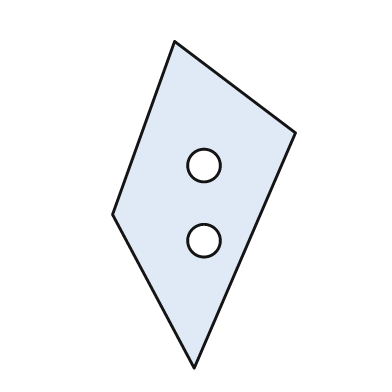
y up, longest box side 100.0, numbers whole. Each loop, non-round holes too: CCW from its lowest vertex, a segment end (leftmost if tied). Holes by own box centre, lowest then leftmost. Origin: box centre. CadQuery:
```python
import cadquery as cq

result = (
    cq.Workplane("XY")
    .moveTo(-3.0, -50.0)
    .lineTo(28.0, 22.0)
    .lineTo(-9.0, 50.0)
    .lineTo(-28.0, -3.0)
    .close()
    .moveTo(0.0, -11.0)
    .circle(5.0)
    .moveTo(0.0, 12.0)
    .circle(5.0)
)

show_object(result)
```